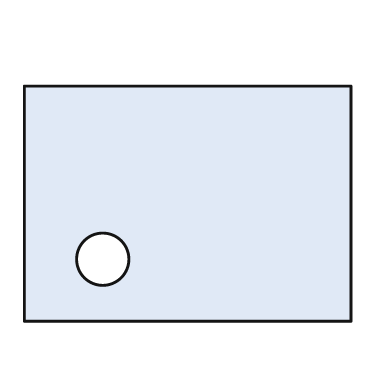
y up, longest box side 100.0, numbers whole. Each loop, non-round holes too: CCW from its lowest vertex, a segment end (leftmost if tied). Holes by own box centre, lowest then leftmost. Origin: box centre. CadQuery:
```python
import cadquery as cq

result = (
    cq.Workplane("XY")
    .moveTo(-50.0, -36.0)
    .lineTo(50.0, -36.0)
    .lineTo(50.0, 36.0)
    .lineTo(-50.0, 36.0)
    .close()
    .moveTo(-26.0, -17.0)
    .circle(8.0)
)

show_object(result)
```